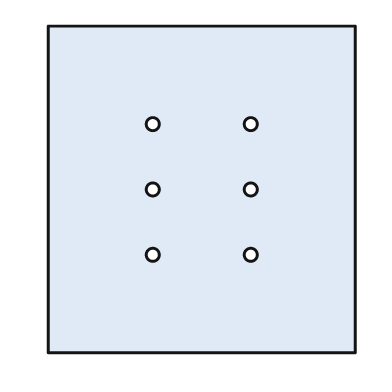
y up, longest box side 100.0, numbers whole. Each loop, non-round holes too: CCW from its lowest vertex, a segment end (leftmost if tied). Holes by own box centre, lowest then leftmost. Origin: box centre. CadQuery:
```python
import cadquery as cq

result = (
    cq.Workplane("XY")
    .moveTo(-47.0, -50.0)
    .lineTo(47.0, -50.0)
    .lineTo(47.0, 50.0)
    .lineTo(-47.0, 50.0)
    .close()
    .moveTo(-15.0, -20.0)
    .circle(2.0)
    .moveTo(15.0, -20.0)
    .circle(2.0)
    .moveTo(-15.0, 0.0)
    .circle(2.0)
    .moveTo(15.0, 0.0)
    .circle(2.0)
    .moveTo(-15.0, 20.0)
    .circle(2.0)
    .moveTo(15.0, 20.0)
    .circle(2.0)
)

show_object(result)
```